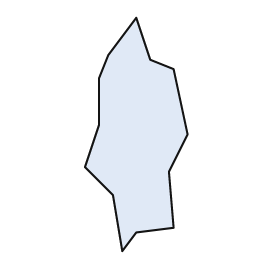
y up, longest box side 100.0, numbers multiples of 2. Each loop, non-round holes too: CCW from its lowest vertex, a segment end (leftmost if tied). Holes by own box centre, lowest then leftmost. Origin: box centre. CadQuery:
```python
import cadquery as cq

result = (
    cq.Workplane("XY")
    .moveTo(-6.0, -50.0)
    .lineTo(0.0, -42.0)
    .lineTo(16.0, -40.0)
    .lineTo(14.0, -16.0)
    .lineTo(22.0, 0.0)
    .lineTo(16.0, 28.0)
    .lineTo(6.0, 32.0)
    .lineTo(0.0, 50.0)
    .lineTo(-12.0, 34.0)
    .lineTo(-16.0, 24.0)
    .lineTo(-16.0, 4.0)
    .lineTo(-22.0, -14.0)
    .lineTo(-10.0, -26.0)
    .close()
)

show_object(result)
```